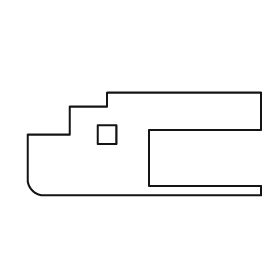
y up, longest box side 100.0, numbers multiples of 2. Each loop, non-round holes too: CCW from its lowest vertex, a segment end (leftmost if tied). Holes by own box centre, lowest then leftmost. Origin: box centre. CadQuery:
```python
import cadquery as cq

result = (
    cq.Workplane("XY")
    .moveTo(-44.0, -22.0)
    .lineTo(50.0, -22.0)
    .lineTo(50.0, -18.0)
    .lineTo(2.0, -18.0)
    .lineTo(2.0, 6.0)
    .lineTo(50.0, 6.0)
    .lineTo(50.0, 22.0)
    .lineTo(-16.0, 22.0)
    .lineTo(-16.0, 16.0)
    .lineTo(-32.0, 16.0)
    .lineTo(-32.0, 4.0)
    .lineTo(-50.0, 4.0)
    .lineTo(-50.0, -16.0)
    .threePointArc((-48.0, -20.0), (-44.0, -22.0))
    .close()
    .moveTo(-20.0, 0.0)
    .lineTo(-12.0, 0.0)
    .lineTo(-12.0, 8.0)
    .lineTo(-20.0, 8.0)
    .close()
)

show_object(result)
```